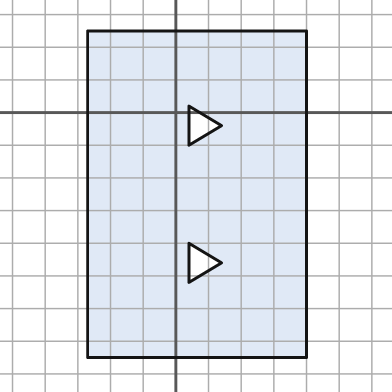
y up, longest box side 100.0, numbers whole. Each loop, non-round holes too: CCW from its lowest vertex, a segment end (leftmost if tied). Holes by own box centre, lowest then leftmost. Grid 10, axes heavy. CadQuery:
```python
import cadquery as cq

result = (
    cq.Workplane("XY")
    .moveTo(-27.0, -75.0)
    .lineTo(40.0, -75.0)
    .lineTo(40.0, 25.0)
    .lineTo(-27.0, 25.0)
    .close()
    .moveTo(4.0, -52.0)
    .lineTo(14.0, -46.0)
    .lineTo(4.0, -40.0)
    .close()
    .moveTo(4.0, -10.0)
    .lineTo(14.0, -4.0)
    .lineTo(4.0, 2.0)
    .close()
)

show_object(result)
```